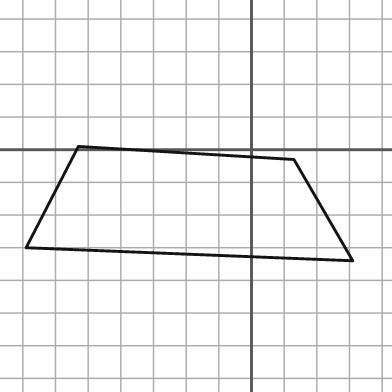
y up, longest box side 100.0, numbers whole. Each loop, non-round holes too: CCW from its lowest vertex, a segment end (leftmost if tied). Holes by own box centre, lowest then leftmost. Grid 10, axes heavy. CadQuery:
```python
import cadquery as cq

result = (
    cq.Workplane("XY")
    .moveTo(31.0, -34.0)
    .lineTo(13.0, -3.0)
    .lineTo(-53.0, 1.0)
    .lineTo(-69.0, -30.0)
    .close()
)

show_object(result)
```